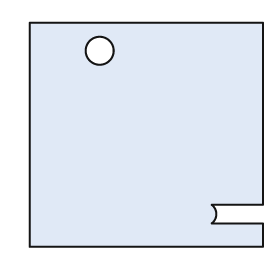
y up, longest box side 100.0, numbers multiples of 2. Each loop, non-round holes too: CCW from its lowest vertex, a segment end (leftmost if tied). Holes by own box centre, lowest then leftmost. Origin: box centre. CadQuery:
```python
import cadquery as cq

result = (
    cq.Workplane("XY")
    .moveTo(-50.0, -48.0)
    .lineTo(50.0, -48.0)
    .lineTo(50.0, -38.0)
    .lineTo(28.0, -38.0)
    .threePointArc((30.0, -34.0), (28.0, -30.0))
    .lineTo(50.0, -30.0)
    .lineTo(50.0, 48.0)
    .lineTo(-50.0, 48.0)
    .close()
    .moveTo(-20.0, 36.0)
    .circle(6.0)
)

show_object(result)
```